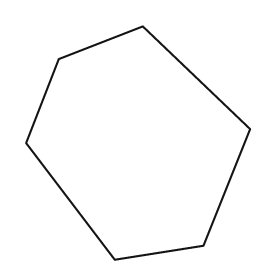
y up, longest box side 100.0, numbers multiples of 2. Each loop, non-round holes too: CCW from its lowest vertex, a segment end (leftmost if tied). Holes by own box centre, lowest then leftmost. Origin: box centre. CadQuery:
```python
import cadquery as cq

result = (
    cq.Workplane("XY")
    .moveTo(-10.0, -50.0)
    .lineTo(28.0, -44.0)
    .lineTo(48.0, 6.0)
    .lineTo(2.0, 50.0)
    .lineTo(-34.0, 36.0)
    .lineTo(-48.0, 0.0)
    .close()
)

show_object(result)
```